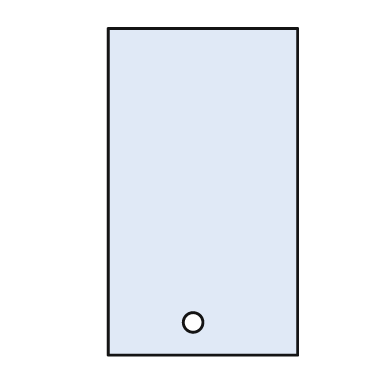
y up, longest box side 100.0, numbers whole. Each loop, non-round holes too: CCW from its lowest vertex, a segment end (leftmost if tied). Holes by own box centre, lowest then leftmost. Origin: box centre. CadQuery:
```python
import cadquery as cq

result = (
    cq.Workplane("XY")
    .moveTo(-29.0, -50.0)
    .lineTo(29.0, -50.0)
    .lineTo(29.0, 50.0)
    .lineTo(-29.0, 50.0)
    .close()
    .moveTo(-3.0, -40.0)
    .circle(3.0)
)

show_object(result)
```